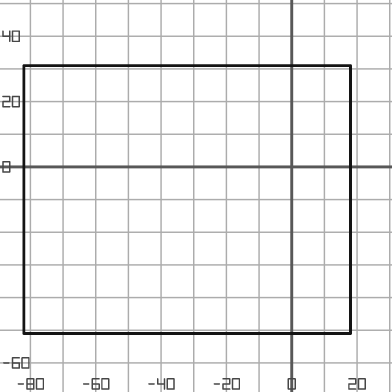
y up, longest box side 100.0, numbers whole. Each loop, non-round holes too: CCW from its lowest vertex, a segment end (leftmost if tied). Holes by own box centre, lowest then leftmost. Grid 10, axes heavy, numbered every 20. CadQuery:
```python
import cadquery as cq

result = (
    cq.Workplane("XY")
    .moveTo(-82.0, -51.0)
    .lineTo(18.0, -51.0)
    .lineTo(18.0, 31.0)
    .lineTo(-82.0, 31.0)
    .close()
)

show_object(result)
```